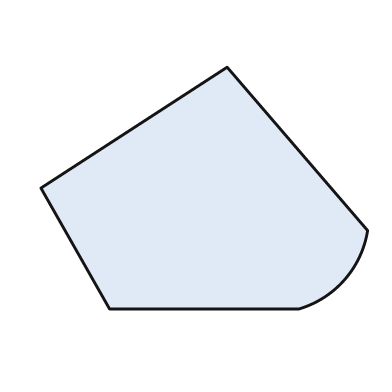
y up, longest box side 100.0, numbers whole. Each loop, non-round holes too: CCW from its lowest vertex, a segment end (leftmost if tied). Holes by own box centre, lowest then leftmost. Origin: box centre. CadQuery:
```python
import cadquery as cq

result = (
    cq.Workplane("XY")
    .moveTo(-29.0, -37.0)
    .lineTo(29.0, -37.0)
    .threePointArc((43.0, -28.0), (50.0, -13.0))
    .lineTo(7.0, 37.0)
    .lineTo(-50.0, 0.0)
    .close()
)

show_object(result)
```